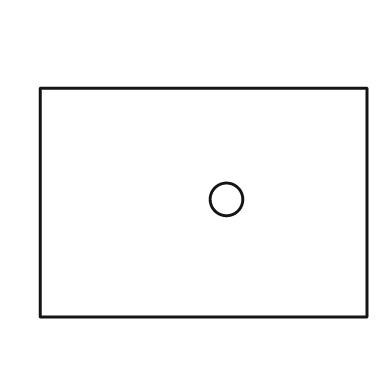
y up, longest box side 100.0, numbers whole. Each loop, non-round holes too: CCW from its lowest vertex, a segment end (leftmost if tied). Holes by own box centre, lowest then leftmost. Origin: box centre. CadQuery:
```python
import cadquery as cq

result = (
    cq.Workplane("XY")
    .moveTo(-50.0, -35.0)
    .lineTo(50.0, -35.0)
    .lineTo(50.0, 35.0)
    .lineTo(-50.0, 35.0)
    .close()
    .moveTo(7.0, 1.0)
    .circle(5.0)
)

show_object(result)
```